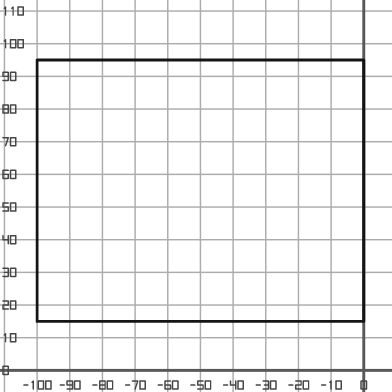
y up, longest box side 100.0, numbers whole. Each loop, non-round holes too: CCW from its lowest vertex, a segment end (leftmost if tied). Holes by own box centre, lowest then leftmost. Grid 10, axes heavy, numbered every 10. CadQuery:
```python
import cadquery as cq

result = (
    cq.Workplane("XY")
    .moveTo(-100.0, 15.0)
    .lineTo(0.0, 15.0)
    .lineTo(0.0, 95.0)
    .lineTo(-100.0, 95.0)
    .close()
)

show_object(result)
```